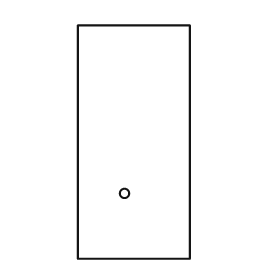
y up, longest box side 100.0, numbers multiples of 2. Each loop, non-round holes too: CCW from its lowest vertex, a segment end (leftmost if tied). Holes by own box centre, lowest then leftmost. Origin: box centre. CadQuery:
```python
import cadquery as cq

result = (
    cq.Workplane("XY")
    .moveTo(-24.0, -50.0)
    .lineTo(24.0, -50.0)
    .lineTo(24.0, 50.0)
    .lineTo(-24.0, 50.0)
    .close()
    .moveTo(-4.0, -22.0)
    .circle(2.0)
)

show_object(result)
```